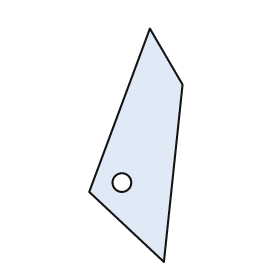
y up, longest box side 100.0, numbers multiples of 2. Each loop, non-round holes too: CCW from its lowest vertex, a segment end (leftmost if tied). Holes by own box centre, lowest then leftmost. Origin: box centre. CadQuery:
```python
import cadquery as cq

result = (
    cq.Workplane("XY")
    .moveTo(12.0, -50.0)
    .lineTo(20.0, 26.0)
    .lineTo(6.0, 50.0)
    .lineTo(-20.0, -20.0)
    .close()
    .moveTo(-6.0, -16.0)
    .circle(4.0)
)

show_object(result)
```